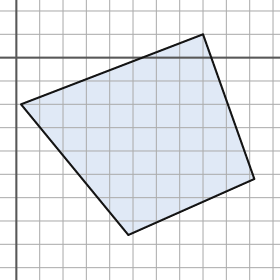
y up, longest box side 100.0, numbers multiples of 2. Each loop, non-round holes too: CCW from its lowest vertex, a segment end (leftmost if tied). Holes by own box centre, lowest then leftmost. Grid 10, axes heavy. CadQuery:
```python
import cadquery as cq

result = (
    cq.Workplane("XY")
    .moveTo(48.0, -76.0)
    .lineTo(102.0, -52.0)
    .lineTo(80.0, 10.0)
    .lineTo(2.0, -20.0)
    .close()
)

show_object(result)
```